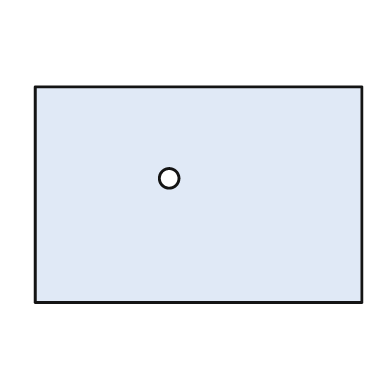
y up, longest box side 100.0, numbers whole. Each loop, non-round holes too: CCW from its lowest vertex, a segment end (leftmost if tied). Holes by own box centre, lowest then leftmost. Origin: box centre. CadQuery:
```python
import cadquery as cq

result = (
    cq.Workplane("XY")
    .moveTo(-50.0, -33.0)
    .lineTo(50.0, -33.0)
    .lineTo(50.0, 33.0)
    .lineTo(-50.0, 33.0)
    .close()
    .moveTo(-9.0, 5.0)
    .circle(3.0)
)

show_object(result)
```